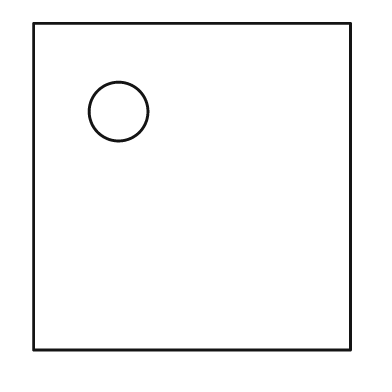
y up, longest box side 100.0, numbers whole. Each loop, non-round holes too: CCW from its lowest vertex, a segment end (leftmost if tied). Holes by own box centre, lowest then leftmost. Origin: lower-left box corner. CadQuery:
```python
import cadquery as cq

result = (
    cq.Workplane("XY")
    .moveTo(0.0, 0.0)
    .lineTo(97.0, 0.0)
    .lineTo(97.0, 100.0)
    .lineTo(0.0, 100.0)
    .close()
    .moveTo(26.0, 73.0)
    .circle(9.0)
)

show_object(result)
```